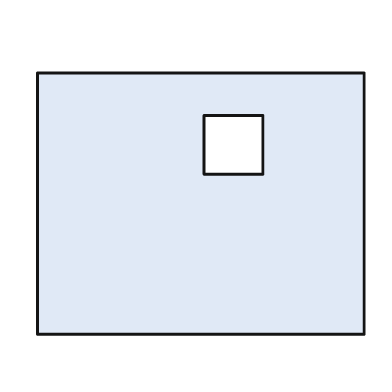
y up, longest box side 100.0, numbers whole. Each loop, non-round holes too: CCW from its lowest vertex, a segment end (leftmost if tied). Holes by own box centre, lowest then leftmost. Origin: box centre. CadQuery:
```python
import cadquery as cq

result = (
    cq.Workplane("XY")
    .moveTo(-50.0, -40.0)
    .lineTo(50.0, -40.0)
    .lineTo(50.0, 40.0)
    .lineTo(-50.0, 40.0)
    .close()
    .moveTo(1.0, 9.0)
    .lineTo(19.0, 9.0)
    .lineTo(19.0, 27.0)
    .lineTo(1.0, 27.0)
    .close()
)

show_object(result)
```